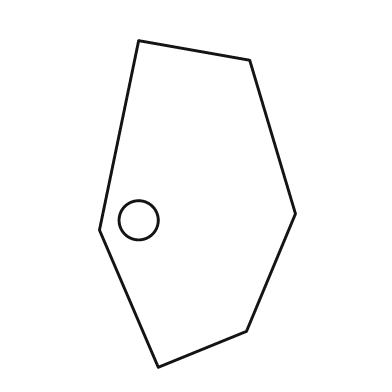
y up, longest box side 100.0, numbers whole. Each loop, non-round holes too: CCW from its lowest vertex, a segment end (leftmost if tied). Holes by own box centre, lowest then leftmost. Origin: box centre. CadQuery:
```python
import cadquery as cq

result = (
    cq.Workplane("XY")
    .moveTo(-12.0, -50.0)
    .lineTo(15.0, -39.0)
    .lineTo(30.0, -3.0)
    .lineTo(16.0, 44.0)
    .lineTo(-18.0, 50.0)
    .lineTo(-30.0, -8.0)
    .close()
    .moveTo(-18.0, -5.0)
    .circle(6.0)
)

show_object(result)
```